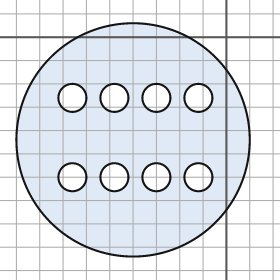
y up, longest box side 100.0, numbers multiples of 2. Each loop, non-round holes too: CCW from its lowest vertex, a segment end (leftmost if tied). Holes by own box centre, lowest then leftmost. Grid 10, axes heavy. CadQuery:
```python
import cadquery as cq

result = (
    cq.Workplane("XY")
    .moveTo(-40.0, -44.0)
    .circle(50.0)
    .moveTo(-66.0, -60.0)
    .circle(6.0)
    .moveTo(-48.0, -60.0)
    .circle(6.0)
    .moveTo(-30.0, -60.0)
    .circle(6.0)
    .moveTo(-12.0, -60.0)
    .circle(6.0)
    .moveTo(-66.0, -26.0)
    .circle(6.0)
    .moveTo(-48.0, -26.0)
    .circle(6.0)
    .moveTo(-30.0, -26.0)
    .circle(6.0)
    .moveTo(-12.0, -26.0)
    .circle(6.0)
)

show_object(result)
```